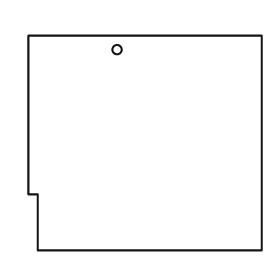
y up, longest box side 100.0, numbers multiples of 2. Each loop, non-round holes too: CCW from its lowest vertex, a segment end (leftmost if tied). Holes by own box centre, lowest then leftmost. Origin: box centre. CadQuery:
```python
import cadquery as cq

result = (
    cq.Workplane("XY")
    .moveTo(-46.0, -46.0)
    .lineTo(50.0, -46.0)
    .lineTo(50.0, 46.0)
    .lineTo(-50.0, 46.0)
    .lineTo(-50.0, -22.0)
    .lineTo(-46.0, -22.0)
    .close()
    .moveTo(-12.0, 40.0)
    .circle(2.0)
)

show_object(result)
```